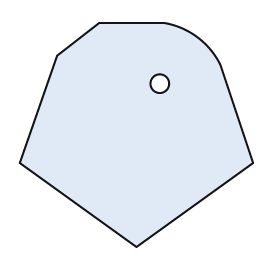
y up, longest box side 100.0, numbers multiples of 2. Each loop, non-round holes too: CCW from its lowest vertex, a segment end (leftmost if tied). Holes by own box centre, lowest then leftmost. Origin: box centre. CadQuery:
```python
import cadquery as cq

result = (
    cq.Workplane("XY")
    .moveTo(0.0, -48.0)
    .lineTo(50.0, -12.0)
    .lineTo(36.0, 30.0)
    .threePointArc((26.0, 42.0), (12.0, 48.0))
    .lineTo(-16.0, 48.0)
    .lineTo(-34.0, 34.0)
    .lineTo(-50.0, -12.0)
    .close()
    .moveTo(10.0, 22.0)
    .circle(4.0)
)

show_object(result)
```